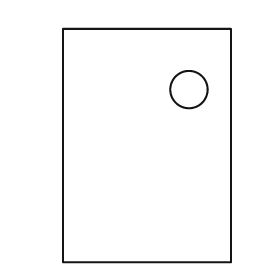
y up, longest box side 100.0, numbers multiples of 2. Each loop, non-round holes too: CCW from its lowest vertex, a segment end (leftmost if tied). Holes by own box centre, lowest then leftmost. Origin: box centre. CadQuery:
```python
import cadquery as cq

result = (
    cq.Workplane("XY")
    .moveTo(-36.0, -50.0)
    .lineTo(36.0, -50.0)
    .lineTo(36.0, 50.0)
    .lineTo(-36.0, 50.0)
    .close()
    .moveTo(18.0, 24.0)
    .circle(8.0)
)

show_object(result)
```